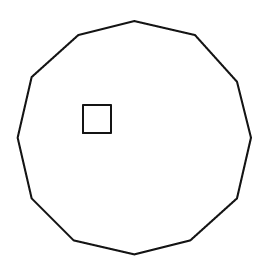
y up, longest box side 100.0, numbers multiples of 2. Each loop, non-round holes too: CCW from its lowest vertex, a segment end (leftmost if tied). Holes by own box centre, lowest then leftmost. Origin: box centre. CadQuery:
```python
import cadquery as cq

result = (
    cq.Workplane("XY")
    .moveTo(0.0, -50.0)
    .lineTo(24.0, -44.0)
    .lineTo(44.0, -26.0)
    .lineTo(50.0, 0.0)
    .lineTo(44.0, 24.0)
    .lineTo(26.0, 44.0)
    .lineTo(0.0, 50.0)
    .lineTo(-24.0, 44.0)
    .lineTo(-44.0, 26.0)
    .lineTo(-50.0, 0.0)
    .lineTo(-44.0, -26.0)
    .lineTo(-26.0, -44.0)
    .close()
    .moveTo(-22.0, 2.0)
    .lineTo(-10.0, 2.0)
    .lineTo(-10.0, 14.0)
    .lineTo(-22.0, 14.0)
    .close()
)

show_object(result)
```